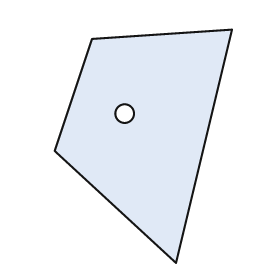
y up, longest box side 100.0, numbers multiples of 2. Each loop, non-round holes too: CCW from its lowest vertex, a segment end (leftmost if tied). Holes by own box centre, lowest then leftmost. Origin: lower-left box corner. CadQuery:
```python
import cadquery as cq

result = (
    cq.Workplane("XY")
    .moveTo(52.0, 0.0)
    .lineTo(76.0, 100.0)
    .lineTo(16.0, 96.0)
    .lineTo(0.0, 48.0)
    .close()
    .moveTo(30.0, 64.0)
    .circle(4.0)
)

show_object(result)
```